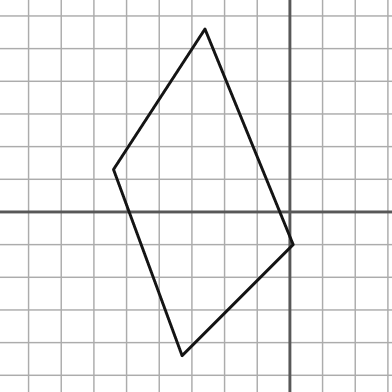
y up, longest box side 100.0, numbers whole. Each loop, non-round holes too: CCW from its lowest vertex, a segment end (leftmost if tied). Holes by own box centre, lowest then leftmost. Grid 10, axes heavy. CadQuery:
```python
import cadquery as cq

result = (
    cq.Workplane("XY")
    .moveTo(-33.0, -44.0)
    .lineTo(1.0, -10.0)
    .lineTo(-26.0, 56.0)
    .lineTo(-54.0, 13.0)
    .close()
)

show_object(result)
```